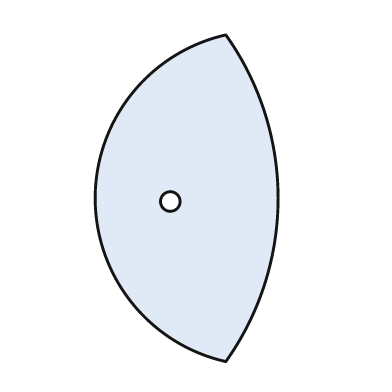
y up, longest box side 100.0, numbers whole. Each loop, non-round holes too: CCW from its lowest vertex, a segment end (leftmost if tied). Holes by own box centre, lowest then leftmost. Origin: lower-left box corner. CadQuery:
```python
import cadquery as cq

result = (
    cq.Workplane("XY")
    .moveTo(40.0, 0.0)
    .threePointArc((56.0, 50.0), (40.0, 100.0))
    .threePointArc((0.0, 50.0), (40.0, 0.0))
    .close()
    .moveTo(23.0, 49.0)
    .circle(3.0)
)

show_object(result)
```